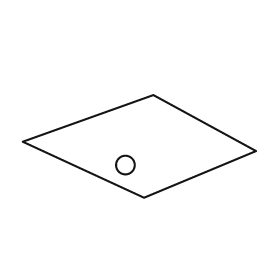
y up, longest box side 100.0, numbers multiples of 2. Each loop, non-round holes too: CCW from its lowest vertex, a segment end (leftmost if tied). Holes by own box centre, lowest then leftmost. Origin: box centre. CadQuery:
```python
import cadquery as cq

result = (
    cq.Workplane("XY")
    .moveTo(2.0, -22.0)
    .lineTo(50.0, -2.0)
    .lineTo(6.0, 22.0)
    .lineTo(-50.0, 2.0)
    .close()
    .moveTo(-6.0, -8.0)
    .circle(4.0)
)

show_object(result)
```